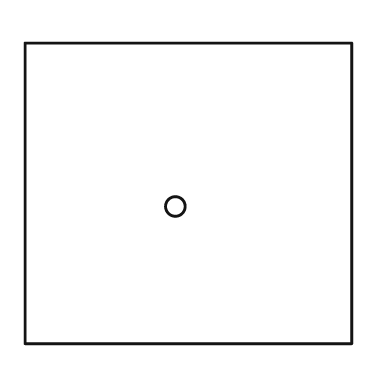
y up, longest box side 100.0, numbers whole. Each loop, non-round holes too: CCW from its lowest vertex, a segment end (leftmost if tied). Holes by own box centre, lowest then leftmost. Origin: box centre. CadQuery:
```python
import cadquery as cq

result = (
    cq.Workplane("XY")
    .moveTo(-50.0, -46.0)
    .lineTo(50.0, -46.0)
    .lineTo(50.0, 46.0)
    .lineTo(-50.0, 46.0)
    .close()
    .moveTo(-4.0, -4.0)
    .circle(3.0)
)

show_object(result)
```